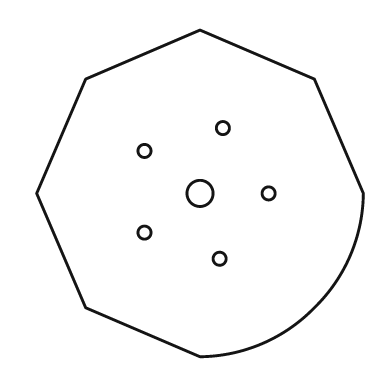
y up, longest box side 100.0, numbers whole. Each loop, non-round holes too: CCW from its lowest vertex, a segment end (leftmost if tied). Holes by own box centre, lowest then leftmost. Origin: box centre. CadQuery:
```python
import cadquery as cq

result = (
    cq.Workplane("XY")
    .moveTo(0.0, -50.0)
    .threePointArc((19.0, -46.0), (35.0, -35.0))
    .threePointArc((46.0, -19.0), (50.0, 0.0))
    .lineTo(35.0, 35.0)
    .lineTo(0.0, 50.0)
    .lineTo(-35.0, 35.0)
    .lineTo(-50.0, 0.0)
    .lineTo(-35.0, -35.0)
    .close()
    .moveTo(6.0, -20.0)
    .circle(2.0)
    .moveTo(-17.0, -12.0)
    .circle(2.0)
    .moveTo(0.0, 0.0)
    .circle(4.0)
    .moveTo(21.0, 0.0)
    .circle(2.0)
    .moveTo(-17.0, 13.0)
    .circle(2.0)
    .moveTo(7.0, 20.0)
    .circle(2.0)
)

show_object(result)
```